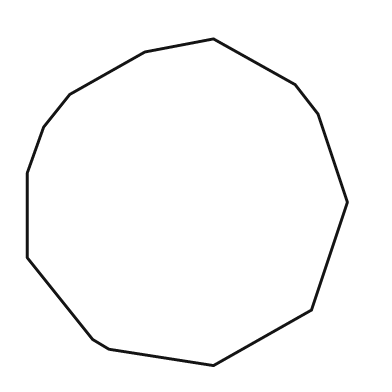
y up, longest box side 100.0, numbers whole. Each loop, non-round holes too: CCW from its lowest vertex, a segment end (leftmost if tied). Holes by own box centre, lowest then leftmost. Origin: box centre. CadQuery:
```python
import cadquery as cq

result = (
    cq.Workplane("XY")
    .moveTo(8.0, -50.0)
    .lineTo(38.0, -33.0)
    .lineTo(49.0, 0.0)
    .lineTo(40.0, 27.0)
    .lineTo(33.0, 36.0)
    .lineTo(8.0, 50.0)
    .lineTo(-13.0, 46.0)
    .lineTo(-36.0, 33.0)
    .lineTo(-44.0, 23.0)
    .lineTo(-49.0, 9.0)
    .lineTo(-49.0, -17.0)
    .lineTo(-29.0, -42.0)
    .lineTo(-24.0, -45.0)
    .close()
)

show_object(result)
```